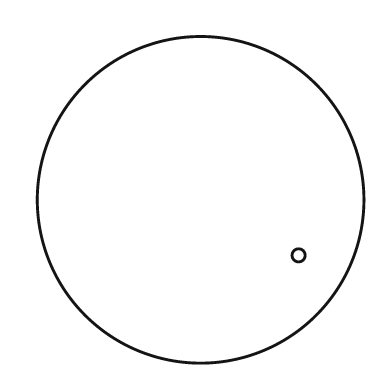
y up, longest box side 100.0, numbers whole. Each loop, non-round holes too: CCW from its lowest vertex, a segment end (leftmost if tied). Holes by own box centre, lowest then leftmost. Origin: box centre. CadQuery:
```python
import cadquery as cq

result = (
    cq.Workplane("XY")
    .moveTo(0.0, 0.0)
    .circle(50.0)
    .moveTo(30.0, -17.0)
    .circle(2.0)
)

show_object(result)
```